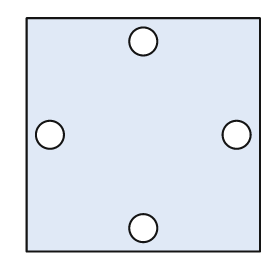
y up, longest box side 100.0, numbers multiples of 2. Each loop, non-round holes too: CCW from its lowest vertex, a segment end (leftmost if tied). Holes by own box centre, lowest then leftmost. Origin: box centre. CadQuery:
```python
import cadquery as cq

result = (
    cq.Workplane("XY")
    .moveTo(-50.0, -50.0)
    .lineTo(50.0, -50.0)
    .lineTo(50.0, 50.0)
    .lineTo(-50.0, 50.0)
    .close()
    .moveTo(0.0, -40.0)
    .circle(6.0)
    .moveTo(-40.0, 0.0)
    .circle(6.0)
    .moveTo(40.0, 0.0)
    .circle(6.0)
    .moveTo(0.0, 40.0)
    .circle(6.0)
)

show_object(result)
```